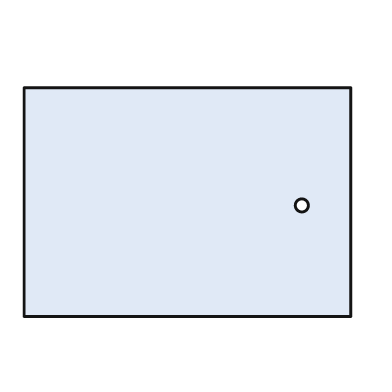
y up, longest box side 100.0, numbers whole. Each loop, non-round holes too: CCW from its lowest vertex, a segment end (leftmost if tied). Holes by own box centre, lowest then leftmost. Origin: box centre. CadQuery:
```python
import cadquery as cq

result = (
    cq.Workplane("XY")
    .moveTo(-50.0, -35.0)
    .lineTo(50.0, -35.0)
    .lineTo(50.0, 35.0)
    .lineTo(-50.0, 35.0)
    .close()
    .moveTo(35.0, -1.0)
    .circle(2.0)
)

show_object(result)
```